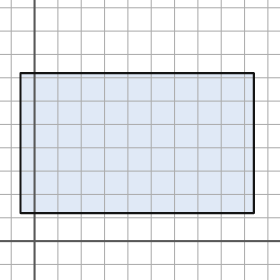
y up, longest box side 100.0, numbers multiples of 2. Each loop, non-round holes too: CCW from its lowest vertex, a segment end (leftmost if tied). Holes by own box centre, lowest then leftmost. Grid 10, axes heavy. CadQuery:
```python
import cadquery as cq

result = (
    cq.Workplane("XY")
    .moveTo(-6.0, 12.0)
    .lineTo(94.0, 12.0)
    .lineTo(94.0, 72.0)
    .lineTo(-6.0, 72.0)
    .close()
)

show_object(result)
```